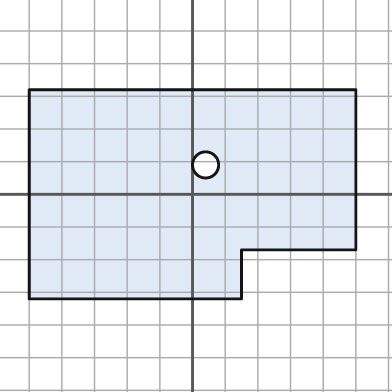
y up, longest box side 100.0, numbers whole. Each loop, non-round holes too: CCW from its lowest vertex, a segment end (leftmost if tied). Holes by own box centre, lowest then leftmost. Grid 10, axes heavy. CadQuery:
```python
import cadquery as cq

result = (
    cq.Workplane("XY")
    .moveTo(-50.0, -32.0)
    .lineTo(15.0, -32.0)
    .lineTo(15.0, -17.0)
    .lineTo(50.0, -17.0)
    .lineTo(50.0, 32.0)
    .lineTo(-50.0, 32.0)
    .close()
    .moveTo(4.0, 9.0)
    .circle(4.0)
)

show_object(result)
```